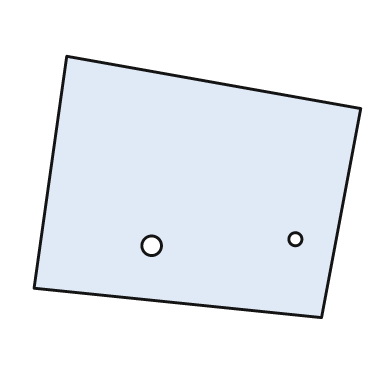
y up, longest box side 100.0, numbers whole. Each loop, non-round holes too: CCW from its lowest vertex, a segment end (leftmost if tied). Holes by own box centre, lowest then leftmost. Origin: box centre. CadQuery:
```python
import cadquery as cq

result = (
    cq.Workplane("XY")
    .moveTo(38.0, -40.0)
    .lineTo(50.0, 24.0)
    .lineTo(-40.0, 40.0)
    .lineTo(-50.0, -31.0)
    .close()
    .moveTo(-14.0, -18.0)
    .circle(3.0)
    .moveTo(30.0, -16.0)
    .circle(2.0)
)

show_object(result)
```